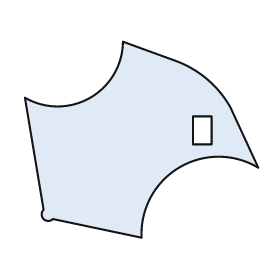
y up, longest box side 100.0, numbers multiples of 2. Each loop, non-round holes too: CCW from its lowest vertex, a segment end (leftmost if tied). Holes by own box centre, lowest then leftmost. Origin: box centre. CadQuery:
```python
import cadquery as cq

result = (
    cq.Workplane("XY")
    .moveTo(0.0, -42.0)
    .threePointArc((16.0, -12.0), (50.0, -12.0))
    .lineTo(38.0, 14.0)
    .threePointArc((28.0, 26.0), (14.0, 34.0))
    .lineTo(-8.0, 42.0)
    .threePointArc((-22.0, 18.0), (-50.0, 18.0))
    .lineTo(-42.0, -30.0)
    .threePointArc((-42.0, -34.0), (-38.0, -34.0))
    .close()
    .moveTo(22.0, -2.0)
    .lineTo(30.0, -2.0)
    .lineTo(30.0, 10.0)
    .lineTo(22.0, 10.0)
    .close()
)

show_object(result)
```